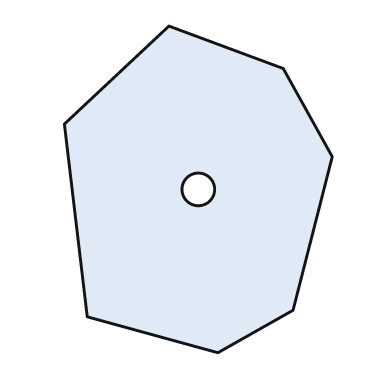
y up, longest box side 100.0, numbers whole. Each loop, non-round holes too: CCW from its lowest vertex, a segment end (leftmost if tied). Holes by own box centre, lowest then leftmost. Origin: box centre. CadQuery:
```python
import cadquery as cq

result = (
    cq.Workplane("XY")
    .moveTo(6.0, -50.0)
    .lineTo(29.0, -37.0)
    .lineTo(41.0, 10.0)
    .lineTo(26.0, 37.0)
    .lineTo(-9.0, 50.0)
    .lineTo(-41.0, 20.0)
    .lineTo(-34.0, -39.0)
    .close()
    .moveTo(0.0, 0.0)
    .circle(5.0)
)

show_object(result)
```